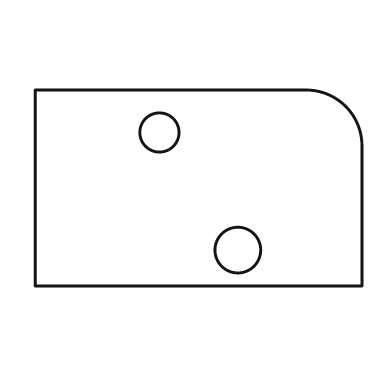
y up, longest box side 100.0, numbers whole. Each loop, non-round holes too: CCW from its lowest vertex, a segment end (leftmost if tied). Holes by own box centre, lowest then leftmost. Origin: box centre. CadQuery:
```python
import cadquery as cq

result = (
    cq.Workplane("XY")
    .moveTo(-50.0, -30.0)
    .lineTo(50.0, -30.0)
    .lineTo(50.0, 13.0)
    .threePointArc((45.0, 25.0), (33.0, 30.0))
    .lineTo(-50.0, 30.0)
    .close()
    .moveTo(12.0, -19.0)
    .circle(7.0)
    .moveTo(-12.0, 17.0)
    .circle(6.0)
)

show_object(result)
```